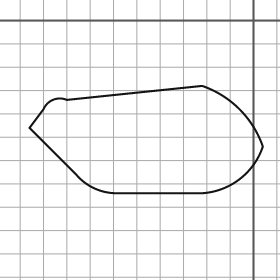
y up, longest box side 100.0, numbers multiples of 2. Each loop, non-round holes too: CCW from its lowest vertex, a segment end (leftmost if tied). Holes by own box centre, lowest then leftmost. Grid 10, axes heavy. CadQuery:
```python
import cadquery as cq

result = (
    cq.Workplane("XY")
    .moveTo(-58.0, -74.0)
    .lineTo(-22.0, -74.0)
    .threePointArc((-6.0, -68.0), (4.0, -54.0))
    .threePointArc((-6.0, -38.0), (-22.0, -28.0))
    .lineTo(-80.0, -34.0)
    .threePointArc((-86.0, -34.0), (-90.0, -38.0))
    .lineTo(-96.0, -46.0)
    .lineTo(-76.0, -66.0)
    .threePointArc((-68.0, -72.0), (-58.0, -74.0))
    .close()
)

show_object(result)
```